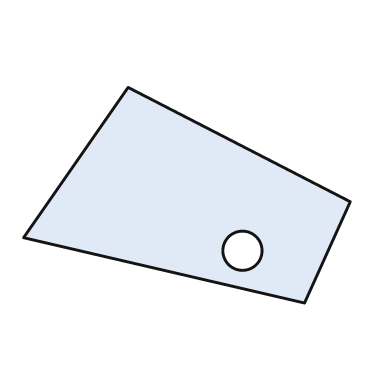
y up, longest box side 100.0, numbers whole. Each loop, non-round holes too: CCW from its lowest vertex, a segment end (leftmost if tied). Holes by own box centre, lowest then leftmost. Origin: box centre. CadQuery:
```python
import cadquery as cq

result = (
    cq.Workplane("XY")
    .moveTo(36.0, -33.0)
    .lineTo(50.0, -2.0)
    .lineTo(-18.0, 33.0)
    .lineTo(-50.0, -13.0)
    .close()
    .moveTo(17.0, -17.0)
    .circle(6.0)
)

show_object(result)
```